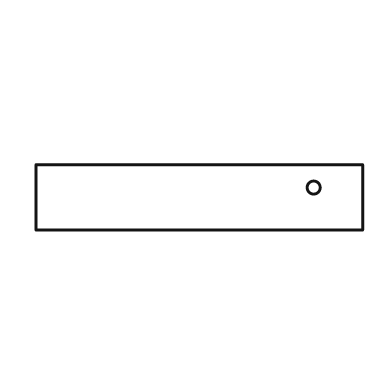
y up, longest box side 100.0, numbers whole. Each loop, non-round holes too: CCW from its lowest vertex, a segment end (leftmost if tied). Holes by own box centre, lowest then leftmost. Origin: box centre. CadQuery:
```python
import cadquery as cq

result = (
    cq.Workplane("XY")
    .moveTo(-50.0, -10.0)
    .lineTo(50.0, -10.0)
    .lineTo(50.0, 10.0)
    .lineTo(-50.0, 10.0)
    .close()
    .moveTo(35.0, 3.0)
    .circle(2.0)
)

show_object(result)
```